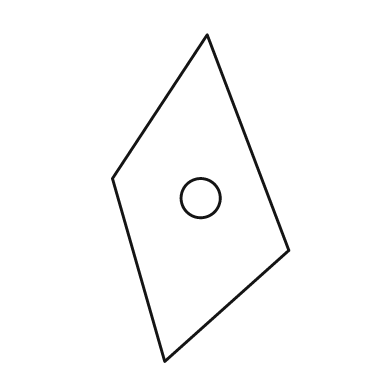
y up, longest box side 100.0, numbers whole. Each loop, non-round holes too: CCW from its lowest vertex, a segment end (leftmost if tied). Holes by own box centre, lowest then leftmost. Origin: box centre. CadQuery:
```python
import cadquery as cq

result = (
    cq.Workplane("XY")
    .moveTo(-11.0, -50.0)
    .lineTo(27.0, -16.0)
    .lineTo(2.0, 50.0)
    .lineTo(-27.0, 6.0)
    .close()
    .moveTo(0.0, 0.0)
    .circle(6.0)
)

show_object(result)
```